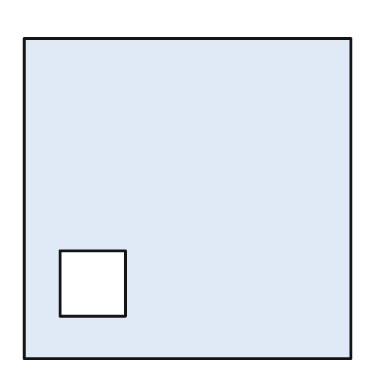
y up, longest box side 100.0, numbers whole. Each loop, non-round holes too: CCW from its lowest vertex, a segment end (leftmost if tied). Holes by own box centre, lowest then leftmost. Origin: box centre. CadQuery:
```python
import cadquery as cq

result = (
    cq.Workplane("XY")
    .moveTo(-50.0, -49.0)
    .lineTo(50.0, -49.0)
    .lineTo(50.0, 49.0)
    .lineTo(-50.0, 49.0)
    .close()
    .moveTo(-39.0, -36.0)
    .lineTo(-19.0, -36.0)
    .lineTo(-19.0, -16.0)
    .lineTo(-39.0, -16.0)
    .close()
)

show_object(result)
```